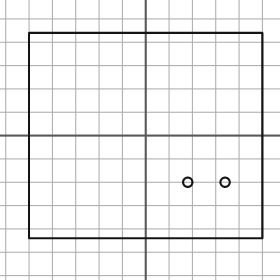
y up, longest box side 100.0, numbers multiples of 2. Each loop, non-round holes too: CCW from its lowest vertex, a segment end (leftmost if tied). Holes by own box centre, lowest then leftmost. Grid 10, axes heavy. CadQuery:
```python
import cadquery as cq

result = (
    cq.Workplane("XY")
    .moveTo(-50.0, -44.0)
    .lineTo(50.0, -44.0)
    .lineTo(50.0, 44.0)
    .lineTo(-50.0, 44.0)
    .close()
    .moveTo(18.0, -20.0)
    .circle(2.0)
    .moveTo(34.0, -20.0)
    .circle(2.0)
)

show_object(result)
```